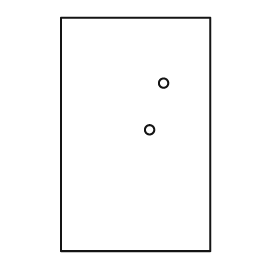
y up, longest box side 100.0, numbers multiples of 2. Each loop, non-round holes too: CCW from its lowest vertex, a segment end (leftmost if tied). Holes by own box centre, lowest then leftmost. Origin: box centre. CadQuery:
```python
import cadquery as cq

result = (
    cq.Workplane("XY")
    .moveTo(-32.0, -50.0)
    .lineTo(32.0, -50.0)
    .lineTo(32.0, 50.0)
    .lineTo(-32.0, 50.0)
    .close()
    .moveTo(6.0, 2.0)
    .circle(2.0)
    .moveTo(12.0, 22.0)
    .circle(2.0)
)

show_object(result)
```